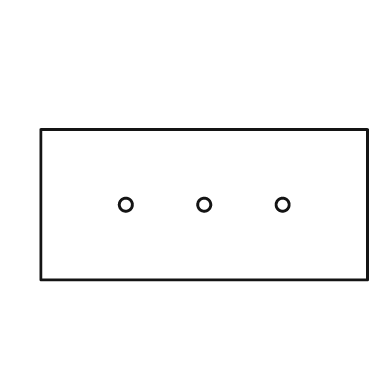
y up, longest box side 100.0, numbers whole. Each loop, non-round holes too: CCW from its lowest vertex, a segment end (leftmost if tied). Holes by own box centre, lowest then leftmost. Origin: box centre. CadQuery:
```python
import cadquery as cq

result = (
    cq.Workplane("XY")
    .moveTo(-50.0, -23.0)
    .lineTo(50.0, -23.0)
    .lineTo(50.0, 23.0)
    .lineTo(-50.0, 23.0)
    .close()
    .moveTo(-24.0, 0.0)
    .circle(2.0)
    .moveTo(0.0, 0.0)
    .circle(2.0)
    .moveTo(24.0, 0.0)
    .circle(2.0)
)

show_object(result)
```